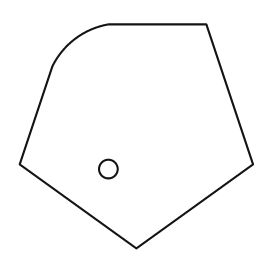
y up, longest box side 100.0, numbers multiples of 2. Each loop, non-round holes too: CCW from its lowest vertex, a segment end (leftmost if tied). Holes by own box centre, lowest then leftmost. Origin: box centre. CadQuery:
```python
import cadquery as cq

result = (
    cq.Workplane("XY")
    .moveTo(0.0, -48.0)
    .lineTo(50.0, -12.0)
    .lineTo(30.0, 48.0)
    .lineTo(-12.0, 48.0)
    .threePointArc((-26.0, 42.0), (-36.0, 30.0))
    .lineTo(-50.0, -12.0)
    .close()
    .moveTo(-12.0, -14.0)
    .circle(4.0)
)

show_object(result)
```